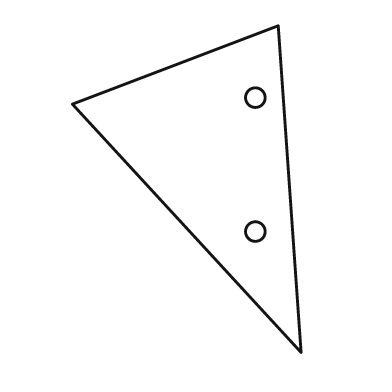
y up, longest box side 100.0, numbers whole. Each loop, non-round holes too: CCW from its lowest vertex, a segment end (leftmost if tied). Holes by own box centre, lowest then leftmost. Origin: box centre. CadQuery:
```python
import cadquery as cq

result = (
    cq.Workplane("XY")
    .moveTo(35.0, -50.0)
    .lineTo(28.0, 50.0)
    .lineTo(-35.0, 26.0)
    .close()
    .moveTo(21.0, -13.0)
    .circle(3.0)
    .moveTo(21.0, 28.0)
    .circle(3.0)
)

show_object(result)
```